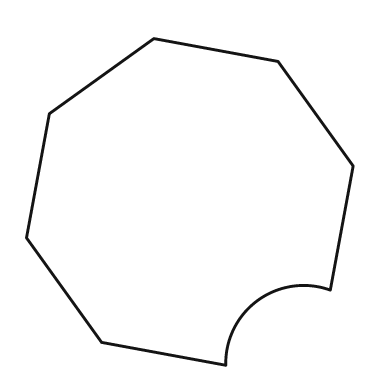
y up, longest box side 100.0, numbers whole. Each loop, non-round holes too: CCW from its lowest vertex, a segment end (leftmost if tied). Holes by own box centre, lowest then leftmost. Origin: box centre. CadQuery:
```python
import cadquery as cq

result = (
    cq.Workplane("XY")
    .moveTo(11.0, -50.0)
    .threePointArc((21.0, -30.0), (43.0, -27.0))
    .lineTo(50.0, 11.0)
    .lineTo(27.0, 43.0)
    .lineTo(-11.0, 50.0)
    .lineTo(-43.0, 27.0)
    .lineTo(-50.0, -11.0)
    .lineTo(-27.0, -43.0)
    .close()
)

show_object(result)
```